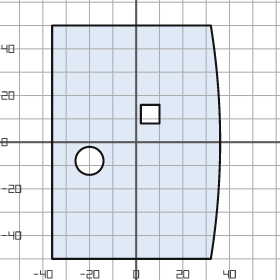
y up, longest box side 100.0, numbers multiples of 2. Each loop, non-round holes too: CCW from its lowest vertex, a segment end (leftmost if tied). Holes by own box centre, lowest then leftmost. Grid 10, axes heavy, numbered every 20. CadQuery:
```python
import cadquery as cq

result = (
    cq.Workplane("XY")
    .moveTo(-36.0, -50.0)
    .lineTo(32.0, -50.0)
    .threePointArc((36.0, 0.0), (32.0, 50.0))
    .lineTo(-36.0, 50.0)
    .close()
    .moveTo(-20.0, -8.0)
    .circle(6.0)
    .moveTo(2.0, 8.0)
    .lineTo(10.0, 8.0)
    .lineTo(10.0, 16.0)
    .lineTo(2.0, 16.0)
    .close()
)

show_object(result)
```